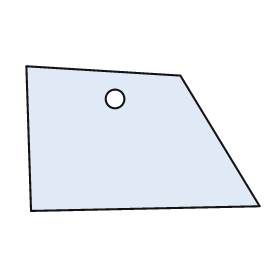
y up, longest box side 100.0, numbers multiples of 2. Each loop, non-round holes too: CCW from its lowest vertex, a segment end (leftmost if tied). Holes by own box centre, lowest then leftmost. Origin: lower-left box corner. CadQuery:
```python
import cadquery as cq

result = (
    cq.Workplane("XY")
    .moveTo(2.0, 0.0)
    .lineTo(100.0, 2.0)
    .lineTo(66.0, 58.0)
    .lineTo(0.0, 62.0)
    .close()
    .moveTo(38.0, 48.0)
    .circle(4.0)
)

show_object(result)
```